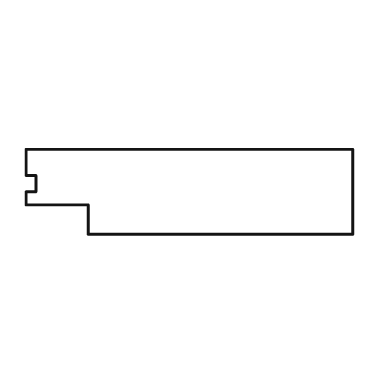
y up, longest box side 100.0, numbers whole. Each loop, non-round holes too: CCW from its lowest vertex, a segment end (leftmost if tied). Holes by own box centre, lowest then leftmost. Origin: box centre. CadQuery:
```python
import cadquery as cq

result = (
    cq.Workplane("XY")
    .moveTo(-31.0, -13.0)
    .lineTo(50.0, -13.0)
    .lineTo(50.0, 13.0)
    .lineTo(-50.0, 13.0)
    .lineTo(-50.0, 5.0)
    .lineTo(-47.0, 5.0)
    .lineTo(-47.0, 0.0)
    .lineTo(-50.0, 0.0)
    .lineTo(-50.0, -4.0)
    .lineTo(-31.0, -4.0)
    .close()
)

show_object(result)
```